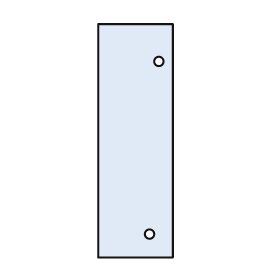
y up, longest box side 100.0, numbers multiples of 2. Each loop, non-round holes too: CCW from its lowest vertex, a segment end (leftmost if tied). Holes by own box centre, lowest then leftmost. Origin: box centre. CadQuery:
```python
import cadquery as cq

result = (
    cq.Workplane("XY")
    .moveTo(-16.0, -50.0)
    .lineTo(16.0, -50.0)
    .lineTo(16.0, 50.0)
    .lineTo(-16.0, 50.0)
    .close()
    .moveTo(6.0, -40.0)
    .circle(2.0)
    .moveTo(10.0, 34.0)
    .circle(2.0)
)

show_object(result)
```